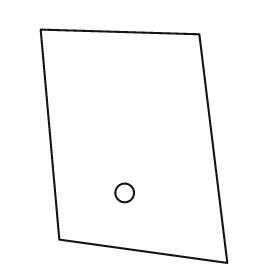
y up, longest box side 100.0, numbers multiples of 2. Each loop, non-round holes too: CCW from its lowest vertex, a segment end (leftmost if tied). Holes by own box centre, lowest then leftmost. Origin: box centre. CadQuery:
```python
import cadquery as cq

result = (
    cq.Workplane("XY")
    .moveTo(40.0, -50.0)
    .lineTo(28.0, 48.0)
    .lineTo(-40.0, 50.0)
    .lineTo(-32.0, -40.0)
    .close()
    .moveTo(-4.0, -20.0)
    .circle(4.0)
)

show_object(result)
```